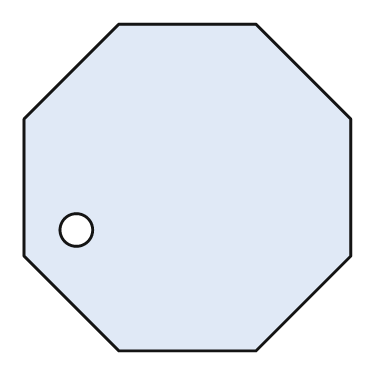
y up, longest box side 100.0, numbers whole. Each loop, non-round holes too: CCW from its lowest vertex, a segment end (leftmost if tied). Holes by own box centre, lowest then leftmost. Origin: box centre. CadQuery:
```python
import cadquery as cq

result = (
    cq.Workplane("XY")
    .moveTo(-21.0, -50.0)
    .lineTo(21.0, -50.0)
    .lineTo(50.0, -21.0)
    .lineTo(50.0, 21.0)
    .lineTo(21.0, 50.0)
    .lineTo(-21.0, 50.0)
    .lineTo(-50.0, 21.0)
    .lineTo(-50.0, -21.0)
    .close()
    .moveTo(-34.0, -13.0)
    .circle(5.0)
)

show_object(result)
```